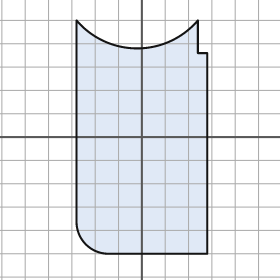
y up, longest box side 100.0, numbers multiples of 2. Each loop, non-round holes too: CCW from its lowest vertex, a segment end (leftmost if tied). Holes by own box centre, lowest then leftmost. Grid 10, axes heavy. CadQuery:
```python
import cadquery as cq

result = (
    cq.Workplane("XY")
    .moveTo(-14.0, -50.0)
    .lineTo(28.0, -50.0)
    .lineTo(28.0, 36.0)
    .lineTo(24.0, 36.0)
    .lineTo(24.0, 50.0)
    .threePointArc((-2.0, 38.0), (-28.0, 50.0))
    .lineTo(-28.0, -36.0)
    .threePointArc((-24.0, -46.0), (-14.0, -50.0))
    .close()
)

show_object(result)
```